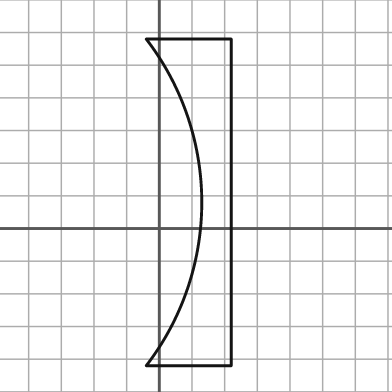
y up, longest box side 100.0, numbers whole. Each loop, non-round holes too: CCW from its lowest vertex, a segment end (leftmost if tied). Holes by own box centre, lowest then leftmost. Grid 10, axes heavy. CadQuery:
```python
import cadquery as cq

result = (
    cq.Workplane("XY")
    .moveTo(-4.0, -42.0)
    .lineTo(22.0, -42.0)
    .lineTo(22.0, 58.0)
    .lineTo(-4.0, 58.0)
    .threePointArc((13.0, 8.0), (-4.0, -42.0))
    .close()
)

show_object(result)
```